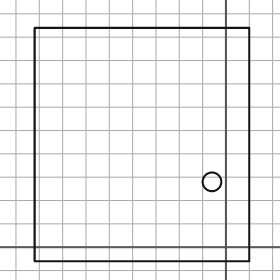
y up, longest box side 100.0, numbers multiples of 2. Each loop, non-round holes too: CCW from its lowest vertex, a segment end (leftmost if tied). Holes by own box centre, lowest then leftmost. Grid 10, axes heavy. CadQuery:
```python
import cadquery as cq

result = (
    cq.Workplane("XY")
    .moveTo(-82.0, -6.0)
    .lineTo(10.0, -6.0)
    .lineTo(10.0, 94.0)
    .lineTo(-82.0, 94.0)
    .close()
    .moveTo(-6.0, 28.0)
    .circle(4.0)
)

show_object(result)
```